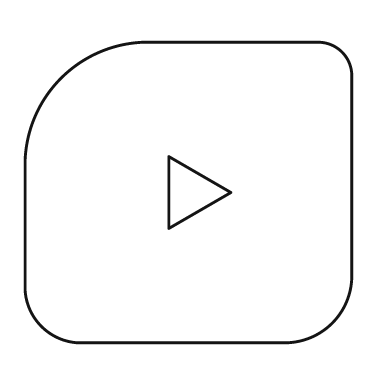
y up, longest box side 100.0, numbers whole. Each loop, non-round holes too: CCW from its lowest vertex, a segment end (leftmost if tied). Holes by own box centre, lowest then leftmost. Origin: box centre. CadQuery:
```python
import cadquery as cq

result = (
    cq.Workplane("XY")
    .moveTo(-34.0, -46.0)
    .lineTo(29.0, -46.0)
    .threePointArc((44.0, -40.0), (50.0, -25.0))
    .lineTo(50.0, 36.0)
    .threePointArc((47.0, 43.0), (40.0, 46.0))
    .lineTo(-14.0, 46.0)
    .threePointArc((-39.0, 35.0), (-50.0, 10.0))
    .lineTo(-50.0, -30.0)
    .threePointArc((-45.0, -41.0), (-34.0, -46.0))
    .close()
    .moveTo(-6.0, -11.0)
    .lineTo(13.0, 0.0)
    .lineTo(-6.0, 11.0)
    .close()
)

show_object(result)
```